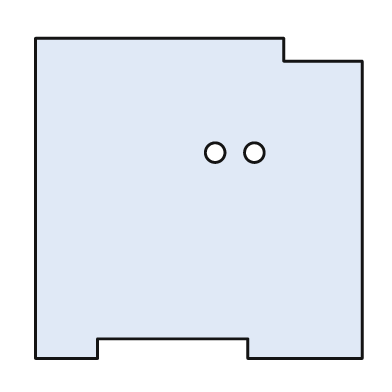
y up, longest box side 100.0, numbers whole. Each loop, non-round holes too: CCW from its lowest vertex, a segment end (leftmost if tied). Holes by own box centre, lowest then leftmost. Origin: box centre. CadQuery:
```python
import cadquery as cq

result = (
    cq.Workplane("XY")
    .moveTo(-50.0, -49.0)
    .lineTo(-31.0, -49.0)
    .lineTo(-31.0, -43.0)
    .lineTo(15.0, -43.0)
    .lineTo(15.0, -49.0)
    .lineTo(50.0, -49.0)
    .lineTo(50.0, 42.0)
    .lineTo(26.0, 42.0)
    .lineTo(26.0, 49.0)
    .lineTo(-50.0, 49.0)
    .close()
    .moveTo(5.0, 14.0)
    .circle(3.0)
    .moveTo(17.0, 14.0)
    .circle(3.0)
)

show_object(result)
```